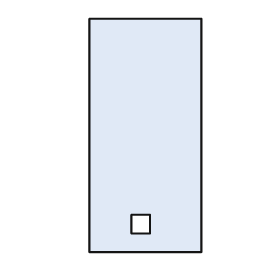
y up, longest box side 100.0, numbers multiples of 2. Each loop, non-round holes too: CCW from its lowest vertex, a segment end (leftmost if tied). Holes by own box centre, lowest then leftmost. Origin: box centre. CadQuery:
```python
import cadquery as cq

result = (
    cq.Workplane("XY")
    .moveTo(-24.0, -50.0)
    .lineTo(24.0, -50.0)
    .lineTo(24.0, 50.0)
    .lineTo(-24.0, 50.0)
    .close()
    .moveTo(-6.0, -42.0)
    .lineTo(2.0, -42.0)
    .lineTo(2.0, -34.0)
    .lineTo(-6.0, -34.0)
    .close()
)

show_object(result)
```